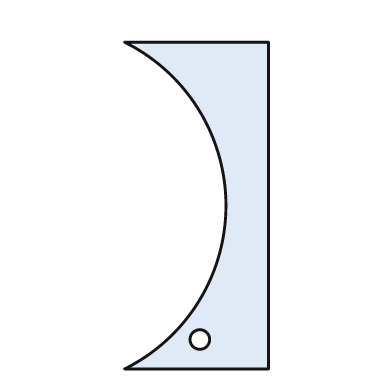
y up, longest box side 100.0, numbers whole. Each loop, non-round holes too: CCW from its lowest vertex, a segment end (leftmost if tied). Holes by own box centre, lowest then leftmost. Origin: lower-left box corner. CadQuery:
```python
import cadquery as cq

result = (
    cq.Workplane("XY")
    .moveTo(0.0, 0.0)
    .lineTo(44.0, 0.0)
    .lineTo(44.0, 100.0)
    .lineTo(0.0, 100.0)
    .threePointArc((31.0, 50.0), (0.0, 0.0))
    .close()
    .moveTo(23.0, 9.0)
    .circle(3.0)
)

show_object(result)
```